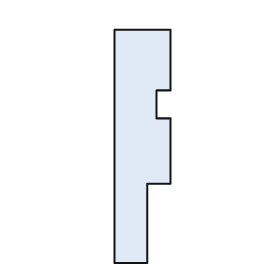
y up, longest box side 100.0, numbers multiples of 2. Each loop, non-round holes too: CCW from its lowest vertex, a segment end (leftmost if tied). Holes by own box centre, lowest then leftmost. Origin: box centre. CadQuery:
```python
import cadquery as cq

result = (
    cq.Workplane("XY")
    .moveTo(-12.0, -50.0)
    .lineTo(2.0, -50.0)
    .lineTo(2.0, -16.0)
    .lineTo(12.0, -16.0)
    .lineTo(12.0, 12.0)
    .lineTo(6.0, 12.0)
    .lineTo(6.0, 24.0)
    .lineTo(12.0, 24.0)
    .lineTo(12.0, 50.0)
    .lineTo(-12.0, 50.0)
    .close()
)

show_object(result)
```